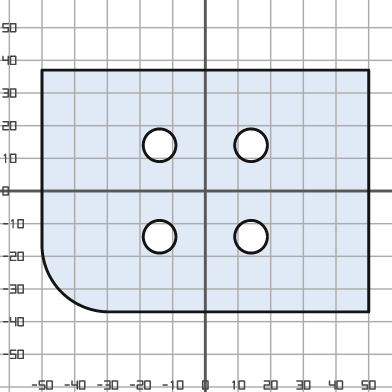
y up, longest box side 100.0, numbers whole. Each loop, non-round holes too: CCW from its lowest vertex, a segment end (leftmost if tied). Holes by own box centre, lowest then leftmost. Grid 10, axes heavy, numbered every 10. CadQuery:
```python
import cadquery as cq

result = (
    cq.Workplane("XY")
    .moveTo(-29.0, -37.0)
    .lineTo(50.0, -37.0)
    .lineTo(50.0, 37.0)
    .lineTo(-50.0, 37.0)
    .lineTo(-50.0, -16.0)
    .threePointArc((-44.0, -31.0), (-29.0, -37.0))
    .close()
    .moveTo(-14.0, -14.0)
    .circle(5.0)
    .moveTo(14.0, -14.0)
    .circle(5.0)
    .moveTo(-14.0, 14.0)
    .circle(5.0)
    .moveTo(14.0, 14.0)
    .circle(5.0)
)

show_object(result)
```